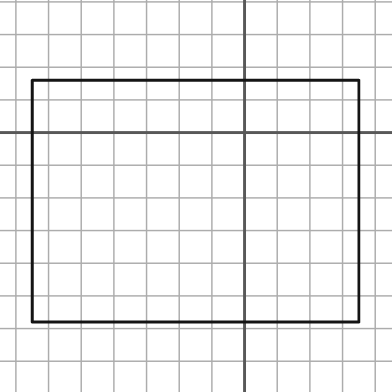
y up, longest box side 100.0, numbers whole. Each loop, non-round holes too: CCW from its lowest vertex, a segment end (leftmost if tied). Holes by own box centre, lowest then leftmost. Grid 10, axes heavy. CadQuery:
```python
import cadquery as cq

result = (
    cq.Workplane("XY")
    .moveTo(-65.0, -58.0)
    .lineTo(35.0, -58.0)
    .lineTo(35.0, 16.0)
    .lineTo(-65.0, 16.0)
    .close()
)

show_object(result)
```